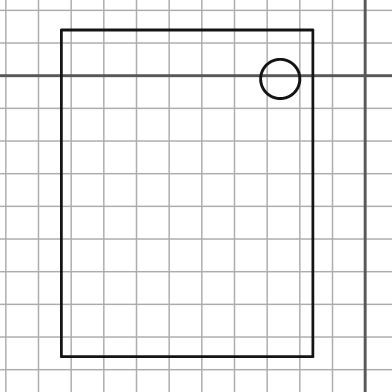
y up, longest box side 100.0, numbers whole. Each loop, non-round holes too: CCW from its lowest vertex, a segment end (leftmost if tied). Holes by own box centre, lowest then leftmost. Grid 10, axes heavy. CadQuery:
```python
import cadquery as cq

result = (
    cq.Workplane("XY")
    .moveTo(-93.0, -86.0)
    .lineTo(-16.0, -86.0)
    .lineTo(-16.0, 14.0)
    .lineTo(-93.0, 14.0)
    .close()
    .moveTo(-26.0, -1.0)
    .circle(6.0)
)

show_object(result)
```